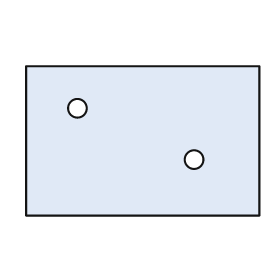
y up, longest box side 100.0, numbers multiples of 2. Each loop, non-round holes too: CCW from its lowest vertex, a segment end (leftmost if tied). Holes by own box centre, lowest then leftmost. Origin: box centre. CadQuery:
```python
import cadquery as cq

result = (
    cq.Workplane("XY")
    .moveTo(-50.0, -32.0)
    .lineTo(50.0, -32.0)
    .lineTo(50.0, 32.0)
    .lineTo(-50.0, 32.0)
    .close()
    .moveTo(22.0, -8.0)
    .circle(4.0)
    .moveTo(-28.0, 14.0)
    .circle(4.0)
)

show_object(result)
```